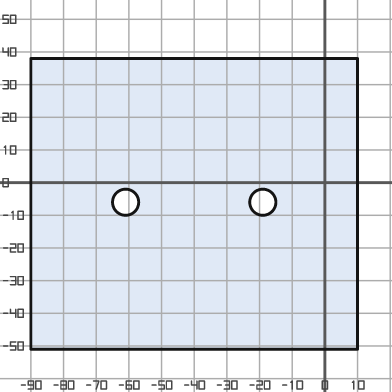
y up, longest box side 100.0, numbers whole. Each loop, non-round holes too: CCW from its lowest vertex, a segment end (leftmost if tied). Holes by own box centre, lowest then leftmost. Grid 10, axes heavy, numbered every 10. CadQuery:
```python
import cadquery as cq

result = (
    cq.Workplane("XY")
    .moveTo(-90.0, -51.0)
    .lineTo(10.0, -51.0)
    .lineTo(10.0, 38.0)
    .lineTo(-90.0, 38.0)
    .close()
    .moveTo(-61.0, -6.0)
    .circle(4.0)
    .moveTo(-19.0, -6.0)
    .circle(4.0)
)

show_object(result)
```